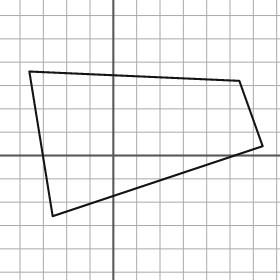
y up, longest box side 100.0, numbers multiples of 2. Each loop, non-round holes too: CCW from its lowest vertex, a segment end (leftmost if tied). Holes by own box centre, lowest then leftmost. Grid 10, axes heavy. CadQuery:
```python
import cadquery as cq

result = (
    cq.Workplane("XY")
    .moveTo(-26.0, -26.0)
    .lineTo(64.0, 4.0)
    .lineTo(54.0, 32.0)
    .lineTo(-36.0, 36.0)
    .close()
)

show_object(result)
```